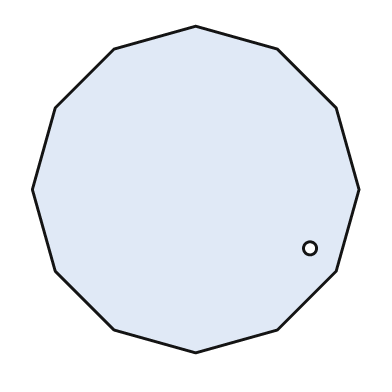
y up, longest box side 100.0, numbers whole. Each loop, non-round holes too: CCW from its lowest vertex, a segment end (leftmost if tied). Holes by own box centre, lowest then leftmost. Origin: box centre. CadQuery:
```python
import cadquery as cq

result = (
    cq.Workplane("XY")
    .moveTo(0.0, -50.0)
    .lineTo(25.0, -43.0)
    .lineTo(43.0, -25.0)
    .lineTo(50.0, 0.0)
    .lineTo(43.0, 25.0)
    .lineTo(25.0, 43.0)
    .lineTo(0.0, 50.0)
    .lineTo(-25.0, 43.0)
    .lineTo(-43.0, 25.0)
    .lineTo(-50.0, 0.0)
    .lineTo(-43.0, -25.0)
    .lineTo(-25.0, -43.0)
    .close()
    .moveTo(35.0, -18.0)
    .circle(2.0)
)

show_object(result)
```